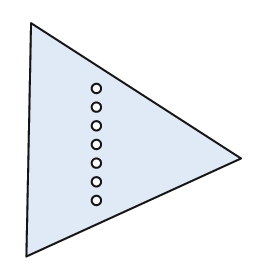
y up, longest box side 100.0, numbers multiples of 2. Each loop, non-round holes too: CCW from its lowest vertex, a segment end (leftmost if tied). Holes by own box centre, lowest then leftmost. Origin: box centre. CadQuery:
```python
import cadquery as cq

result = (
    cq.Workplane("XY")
    .moveTo(-46.0, -50.0)
    .lineTo(46.0, -8.0)
    .lineTo(-44.0, 50.0)
    .close()
    .moveTo(-16.0, -26.0)
    .circle(2.0)
    .moveTo(-16.0, -18.0)
    .circle(2.0)
    .moveTo(-16.0, -10.0)
    .circle(2.0)
    .moveTo(-16.0, -2.0)
    .circle(2.0)
    .moveTo(-16.0, 6.0)
    .circle(2.0)
    .moveTo(-16.0, 14.0)
    .circle(2.0)
    .moveTo(-16.0, 22.0)
    .circle(2.0)
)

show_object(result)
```